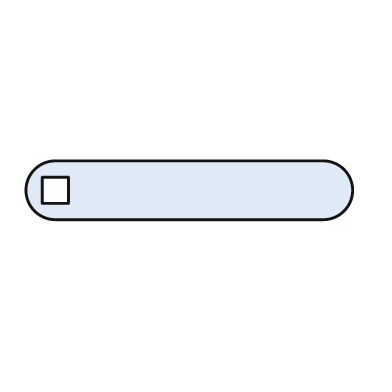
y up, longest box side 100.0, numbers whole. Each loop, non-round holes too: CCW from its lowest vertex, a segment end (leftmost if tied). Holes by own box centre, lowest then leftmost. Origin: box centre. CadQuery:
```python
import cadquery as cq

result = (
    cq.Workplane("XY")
    .moveTo(-41.0, -9.0)
    .lineTo(41.0, -9.0)
    .threePointArc((50.0, 0.0), (41.0, 9.0))
    .lineTo(-41.0, 9.0)
    .threePointArc((-50.0, 0.0), (-41.0, -9.0))
    .close()
    .moveTo(-45.0, -4.0)
    .lineTo(-37.0, -4.0)
    .lineTo(-37.0, 4.0)
    .lineTo(-45.0, 4.0)
    .close()
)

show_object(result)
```